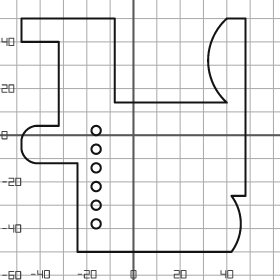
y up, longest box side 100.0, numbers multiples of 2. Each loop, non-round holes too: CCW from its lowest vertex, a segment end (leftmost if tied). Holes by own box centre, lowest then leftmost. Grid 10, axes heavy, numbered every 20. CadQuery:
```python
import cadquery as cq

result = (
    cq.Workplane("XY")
    .moveTo(-24.0, -50.0)
    .lineTo(42.0, -50.0)
    .threePointArc((46.0, -38.0), (42.0, -26.0))
    .lineTo(48.0, -26.0)
    .lineTo(48.0, 50.0)
    .lineTo(40.0, 50.0)
    .threePointArc((32.0, 32.0), (40.0, 14.0))
    .lineTo(-8.0, 14.0)
    .lineTo(-8.0, 50.0)
    .lineTo(-48.0, 50.0)
    .lineTo(-48.0, 40.0)
    .lineTo(-32.0, 40.0)
    .lineTo(-32.0, 4.0)
    .lineTo(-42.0, 4.0)
    .threePointArc((-46.0, 2.0), (-48.0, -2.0))
    .lineTo(-48.0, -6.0)
    .threePointArc((-46.0, -10.0), (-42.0, -12.0))
    .lineTo(-24.0, -12.0)
    .close()
    .moveTo(-16.0, -38.0)
    .circle(2.0)
    .moveTo(-16.0, -30.0)
    .circle(2.0)
    .moveTo(-16.0, -22.0)
    .circle(2.0)
    .moveTo(-16.0, -14.0)
    .circle(2.0)
    .moveTo(-16.0, -6.0)
    .circle(2.0)
    .moveTo(-16.0, 2.0)
    .circle(2.0)
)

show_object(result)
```